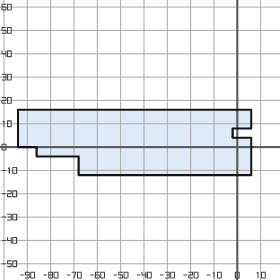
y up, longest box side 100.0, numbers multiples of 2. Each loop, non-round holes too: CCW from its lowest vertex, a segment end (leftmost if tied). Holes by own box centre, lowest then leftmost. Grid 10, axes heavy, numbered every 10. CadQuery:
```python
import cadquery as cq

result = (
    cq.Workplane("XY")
    .moveTo(-68.0, -12.0)
    .lineTo(6.0, -12.0)
    .lineTo(6.0, 4.0)
    .lineTo(-2.0, 4.0)
    .lineTo(-2.0, 8.0)
    .lineTo(6.0, 8.0)
    .lineTo(6.0, 16.0)
    .lineTo(-94.0, 16.0)
    .lineTo(-94.0, 0.0)
    .lineTo(-86.0, 0.0)
    .lineTo(-86.0, -4.0)
    .lineTo(-68.0, -4.0)
    .close()
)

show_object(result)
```